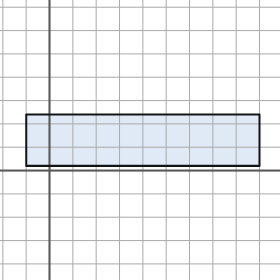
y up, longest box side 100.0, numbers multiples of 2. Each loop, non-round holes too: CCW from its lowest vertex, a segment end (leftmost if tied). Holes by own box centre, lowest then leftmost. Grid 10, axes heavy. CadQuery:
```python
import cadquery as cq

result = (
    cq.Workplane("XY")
    .moveTo(-10.0, 2.0)
    .lineTo(90.0, 2.0)
    .lineTo(90.0, 24.0)
    .lineTo(-10.0, 24.0)
    .close()
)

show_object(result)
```